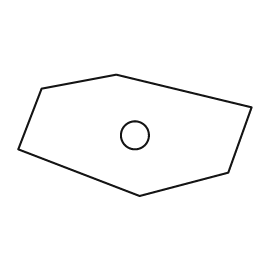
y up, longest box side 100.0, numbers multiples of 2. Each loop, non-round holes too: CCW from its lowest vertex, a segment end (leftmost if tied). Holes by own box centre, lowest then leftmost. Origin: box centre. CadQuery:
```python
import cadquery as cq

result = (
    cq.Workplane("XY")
    .moveTo(2.0, -26.0)
    .lineTo(40.0, -16.0)
    .lineTo(50.0, 12.0)
    .lineTo(-8.0, 26.0)
    .lineTo(-40.0, 20.0)
    .lineTo(-50.0, -6.0)
    .close()
    .moveTo(0.0, 0.0)
    .circle(6.0)
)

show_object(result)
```